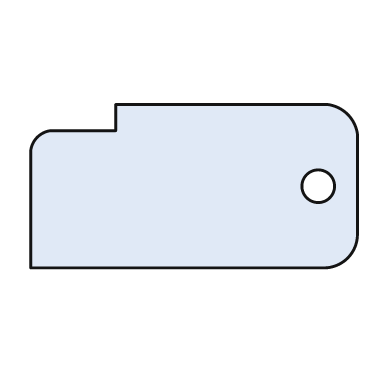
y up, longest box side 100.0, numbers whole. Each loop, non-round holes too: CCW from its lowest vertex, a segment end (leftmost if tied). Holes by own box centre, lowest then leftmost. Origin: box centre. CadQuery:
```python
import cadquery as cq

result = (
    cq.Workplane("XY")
    .moveTo(-50.0, -25.0)
    .lineTo(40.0, -25.0)
    .threePointArc((47.0, -22.0), (50.0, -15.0))
    .lineTo(50.0, 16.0)
    .threePointArc((47.0, 22.0), (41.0, 25.0))
    .lineTo(-24.0, 25.0)
    .lineTo(-24.0, 17.0)
    .lineTo(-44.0, 17.0)
    .threePointArc((-48.0, 15.0), (-50.0, 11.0))
    .close()
    .moveTo(38.0, 0.0)
    .circle(5.0)
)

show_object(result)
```